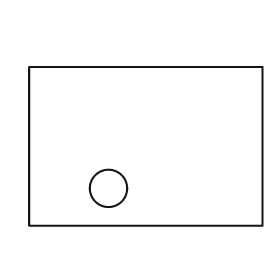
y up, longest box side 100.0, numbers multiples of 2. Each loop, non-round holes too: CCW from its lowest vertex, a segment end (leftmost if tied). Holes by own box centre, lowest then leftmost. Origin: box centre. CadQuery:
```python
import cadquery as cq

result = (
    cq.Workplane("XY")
    .moveTo(-50.0, -34.0)
    .lineTo(50.0, -34.0)
    .lineTo(50.0, 34.0)
    .lineTo(-50.0, 34.0)
    .close()
    .moveTo(-16.0, -18.0)
    .circle(8.0)
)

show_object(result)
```